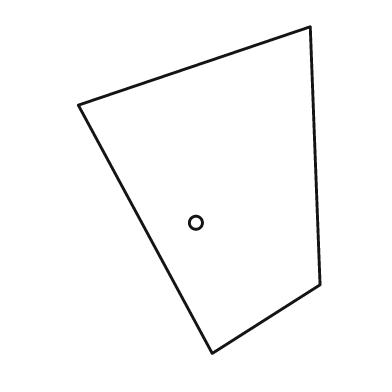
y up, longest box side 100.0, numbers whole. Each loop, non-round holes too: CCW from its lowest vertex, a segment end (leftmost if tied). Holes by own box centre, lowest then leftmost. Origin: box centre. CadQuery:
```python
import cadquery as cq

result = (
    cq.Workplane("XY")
    .moveTo(4.0, -50.0)
    .lineTo(37.0, -29.0)
    .lineTo(34.0, 50.0)
    .lineTo(-37.0, 26.0)
    .close()
    .moveTo(-1.0, -10.0)
    .circle(2.0)
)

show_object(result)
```